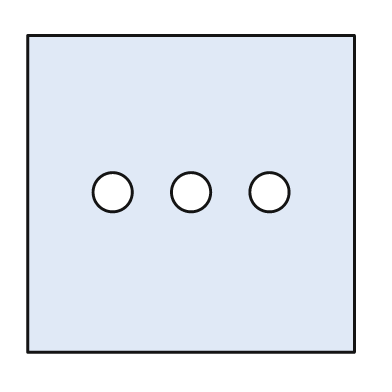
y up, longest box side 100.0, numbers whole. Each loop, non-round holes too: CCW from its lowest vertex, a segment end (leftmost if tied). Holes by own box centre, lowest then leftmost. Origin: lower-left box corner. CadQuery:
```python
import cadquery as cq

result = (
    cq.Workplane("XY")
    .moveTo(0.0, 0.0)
    .lineTo(100.0, 0.0)
    .lineTo(100.0, 97.0)
    .lineTo(0.0, 97.0)
    .close()
    .moveTo(26.0, 49.0)
    .circle(6.0)
    .moveTo(50.0, 49.0)
    .circle(6.0)
    .moveTo(74.0, 49.0)
    .circle(6.0)
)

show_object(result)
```